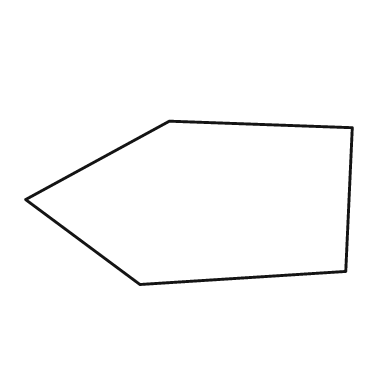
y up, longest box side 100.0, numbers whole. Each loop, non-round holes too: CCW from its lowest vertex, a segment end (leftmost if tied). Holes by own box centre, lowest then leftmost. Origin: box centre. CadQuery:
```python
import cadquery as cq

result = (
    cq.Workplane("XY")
    .moveTo(-15.0, -25.0)
    .lineTo(48.0, -21.0)
    .lineTo(50.0, 23.0)
    .lineTo(-6.0, 25.0)
    .lineTo(-50.0, 1.0)
    .close()
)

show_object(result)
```